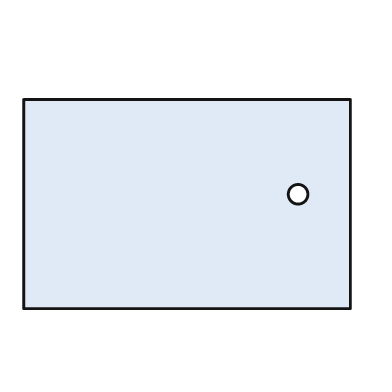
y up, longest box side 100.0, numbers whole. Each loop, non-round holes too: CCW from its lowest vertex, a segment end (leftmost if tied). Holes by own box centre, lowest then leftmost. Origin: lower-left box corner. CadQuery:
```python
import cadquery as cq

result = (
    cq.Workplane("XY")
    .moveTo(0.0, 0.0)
    .lineTo(100.0, 0.0)
    .lineTo(100.0, 64.0)
    .lineTo(0.0, 64.0)
    .close()
    .moveTo(84.0, 35.0)
    .circle(3.0)
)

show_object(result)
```